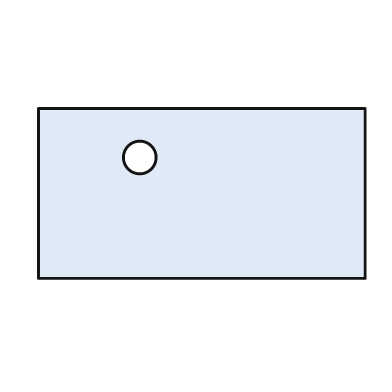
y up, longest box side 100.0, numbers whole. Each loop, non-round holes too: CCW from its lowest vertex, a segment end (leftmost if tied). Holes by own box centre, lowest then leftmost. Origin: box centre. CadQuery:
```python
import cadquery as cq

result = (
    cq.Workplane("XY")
    .moveTo(-50.0, -26.0)
    .lineTo(50.0, -26.0)
    .lineTo(50.0, 26.0)
    .lineTo(-50.0, 26.0)
    .close()
    .moveTo(-19.0, 11.0)
    .circle(5.0)
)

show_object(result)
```